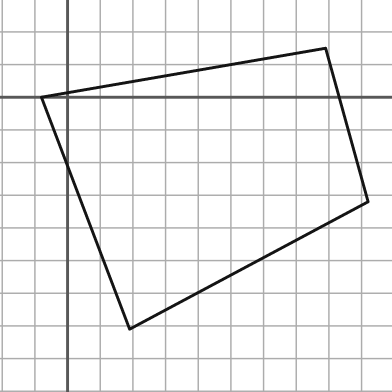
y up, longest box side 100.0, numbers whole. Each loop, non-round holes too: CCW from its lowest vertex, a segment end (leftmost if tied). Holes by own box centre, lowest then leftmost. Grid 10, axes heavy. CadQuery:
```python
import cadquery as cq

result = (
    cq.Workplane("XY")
    .moveTo(19.0, -71.0)
    .lineTo(92.0, -32.0)
    .lineTo(79.0, 15.0)
    .lineTo(-8.0, 0.0)
    .close()
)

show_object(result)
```